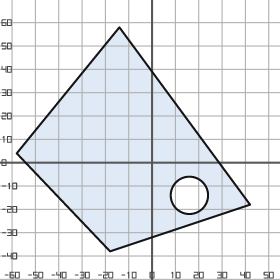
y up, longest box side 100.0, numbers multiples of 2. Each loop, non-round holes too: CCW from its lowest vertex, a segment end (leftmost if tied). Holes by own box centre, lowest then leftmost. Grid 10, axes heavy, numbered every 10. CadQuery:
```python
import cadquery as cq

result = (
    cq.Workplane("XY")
    .moveTo(-18.0, -38.0)
    .lineTo(42.0, -18.0)
    .lineTo(-14.0, 58.0)
    .lineTo(-58.0, 4.0)
    .close()
    .moveTo(16.0, -14.0)
    .circle(8.0)
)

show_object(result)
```